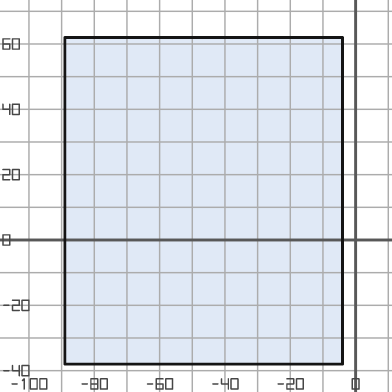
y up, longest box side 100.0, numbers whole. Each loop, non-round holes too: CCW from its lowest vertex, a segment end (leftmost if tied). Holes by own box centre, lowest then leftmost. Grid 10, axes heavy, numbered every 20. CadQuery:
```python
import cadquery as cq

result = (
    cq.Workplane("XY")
    .moveTo(-89.0, -38.0)
    .lineTo(-4.0, -38.0)
    .lineTo(-4.0, 62.0)
    .lineTo(-89.0, 62.0)
    .close()
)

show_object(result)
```